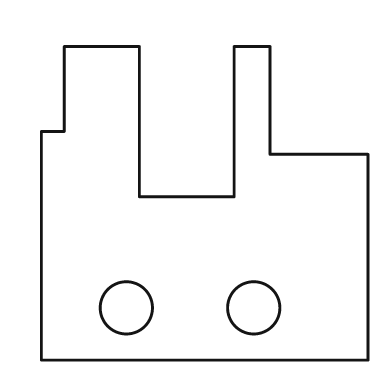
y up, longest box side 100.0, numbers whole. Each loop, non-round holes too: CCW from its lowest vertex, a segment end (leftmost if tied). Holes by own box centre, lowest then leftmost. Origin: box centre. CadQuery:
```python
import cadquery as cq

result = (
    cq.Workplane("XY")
    .moveTo(-50.0, -48.0)
    .lineTo(50.0, -48.0)
    .lineTo(50.0, 15.0)
    .lineTo(20.0, 15.0)
    .lineTo(20.0, 48.0)
    .lineTo(9.0, 48.0)
    .lineTo(9.0, 2.0)
    .lineTo(-20.0, 2.0)
    .lineTo(-20.0, 48.0)
    .lineTo(-43.0, 48.0)
    .lineTo(-43.0, 22.0)
    .lineTo(-50.0, 22.0)
    .close()
    .moveTo(-24.0, -32.0)
    .circle(8.0)
    .moveTo(15.0, -32.0)
    .circle(8.0)
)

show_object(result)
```